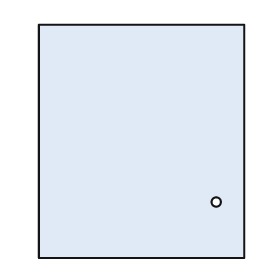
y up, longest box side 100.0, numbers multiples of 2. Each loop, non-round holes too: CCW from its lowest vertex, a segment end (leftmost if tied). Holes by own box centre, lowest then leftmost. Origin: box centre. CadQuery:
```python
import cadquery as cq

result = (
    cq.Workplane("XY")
    .moveTo(-44.0, -50.0)
    .lineTo(44.0, -50.0)
    .lineTo(44.0, 50.0)
    .lineTo(-44.0, 50.0)
    .close()
    .moveTo(32.0, -26.0)
    .circle(2.0)
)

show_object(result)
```